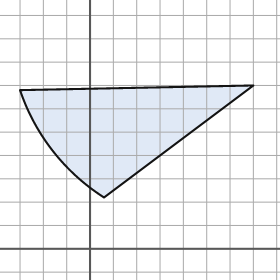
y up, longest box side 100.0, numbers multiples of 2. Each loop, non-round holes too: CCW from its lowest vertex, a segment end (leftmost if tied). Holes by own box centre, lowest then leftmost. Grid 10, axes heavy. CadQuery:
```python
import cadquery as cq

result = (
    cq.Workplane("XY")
    .moveTo(6.0, 22.0)
    .lineTo(70.0, 70.0)
    .lineTo(-30.0, 68.0)
    .threePointArc((-16.0, 42.0), (6.0, 22.0))
    .close()
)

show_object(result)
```